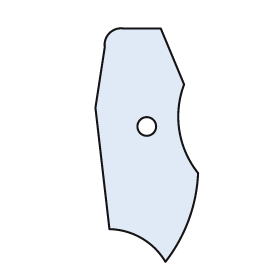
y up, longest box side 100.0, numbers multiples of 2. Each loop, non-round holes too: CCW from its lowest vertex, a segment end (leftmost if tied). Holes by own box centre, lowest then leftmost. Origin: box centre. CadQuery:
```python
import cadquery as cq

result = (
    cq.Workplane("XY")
    .moveTo(8.0, -50.0)
    .threePointArc((18.0, -32.0), (22.0, -12.0))
    .threePointArc((14.0, 6.0), (16.0, 26.0))
    .lineTo(6.0, 50.0)
    .lineTo(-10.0, 50.0)
    .threePointArc((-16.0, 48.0), (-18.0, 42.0))
    .lineTo(-22.0, 16.0)
    .lineTo(-16.0, -36.0)
    .threePointArc((-2.0, -40.0), (8.0, -50.0))
    .close()
    .moveTo(0.0, 8.0)
    .circle(4.0)
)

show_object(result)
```